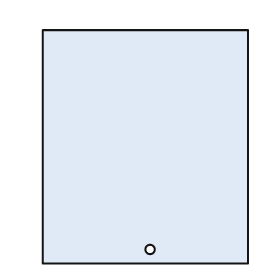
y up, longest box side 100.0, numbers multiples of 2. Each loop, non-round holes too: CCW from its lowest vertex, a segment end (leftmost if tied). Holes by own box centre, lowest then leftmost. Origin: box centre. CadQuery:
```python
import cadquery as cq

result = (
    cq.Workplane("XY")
    .moveTo(-44.0, -50.0)
    .lineTo(44.0, -50.0)
    .lineTo(44.0, 50.0)
    .lineTo(-44.0, 50.0)
    .close()
    .moveTo(2.0, -44.0)
    .circle(2.0)
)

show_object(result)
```